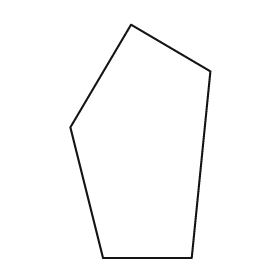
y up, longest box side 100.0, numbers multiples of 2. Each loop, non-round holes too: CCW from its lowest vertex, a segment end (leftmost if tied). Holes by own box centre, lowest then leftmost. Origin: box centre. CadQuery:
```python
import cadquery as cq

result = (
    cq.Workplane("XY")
    .moveTo(-16.0, -50.0)
    .lineTo(22.0, -50.0)
    .lineTo(30.0, 30.0)
    .lineTo(-4.0, 50.0)
    .lineTo(-30.0, 6.0)
    .close()
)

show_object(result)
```